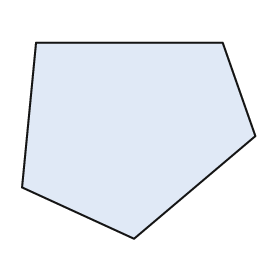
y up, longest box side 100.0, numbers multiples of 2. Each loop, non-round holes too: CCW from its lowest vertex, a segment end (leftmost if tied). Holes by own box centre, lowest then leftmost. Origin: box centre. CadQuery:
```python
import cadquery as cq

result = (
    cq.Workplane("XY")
    .moveTo(-2.0, -42.0)
    .lineTo(50.0, 2.0)
    .lineTo(36.0, 42.0)
    .lineTo(-44.0, 42.0)
    .lineTo(-50.0, -20.0)
    .close()
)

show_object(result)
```